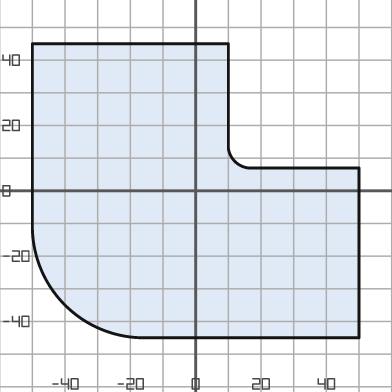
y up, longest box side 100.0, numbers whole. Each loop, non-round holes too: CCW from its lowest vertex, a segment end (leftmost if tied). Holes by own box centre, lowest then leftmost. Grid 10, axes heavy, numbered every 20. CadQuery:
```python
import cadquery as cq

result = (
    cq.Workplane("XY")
    .moveTo(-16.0, -45.0)
    .lineTo(50.0, -45.0)
    .lineTo(50.0, 7.0)
    .lineTo(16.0, 7.0)
    .threePointArc((12.0, 9.0), (10.0, 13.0))
    .lineTo(10.0, 45.0)
    .lineTo(-50.0, 45.0)
    .lineTo(-50.0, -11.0)
    .threePointArc((-40.0, -35.0), (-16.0, -45.0))
    .close()
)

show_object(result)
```